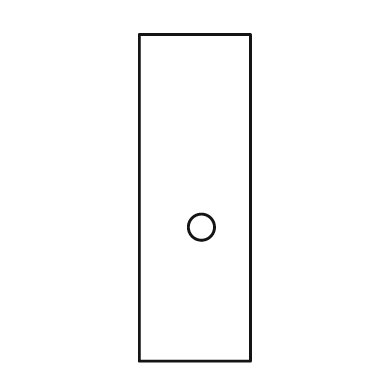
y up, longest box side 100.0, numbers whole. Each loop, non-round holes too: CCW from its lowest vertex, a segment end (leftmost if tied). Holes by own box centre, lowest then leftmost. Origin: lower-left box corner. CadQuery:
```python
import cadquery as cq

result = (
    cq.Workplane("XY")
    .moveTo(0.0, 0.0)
    .lineTo(34.0, 0.0)
    .lineTo(34.0, 100.0)
    .lineTo(0.0, 100.0)
    .close()
    .moveTo(19.0, 41.0)
    .circle(4.0)
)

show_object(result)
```